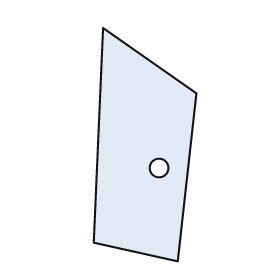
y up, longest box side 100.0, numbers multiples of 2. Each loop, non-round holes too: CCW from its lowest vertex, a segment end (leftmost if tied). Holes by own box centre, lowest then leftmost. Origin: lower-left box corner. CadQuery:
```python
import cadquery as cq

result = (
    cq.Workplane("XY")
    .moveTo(36.0, 0.0)
    .lineTo(44.0, 72.0)
    .lineTo(4.0, 100.0)
    .lineTo(0.0, 8.0)
    .close()
    .moveTo(28.0, 40.0)
    .circle(4.0)
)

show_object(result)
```